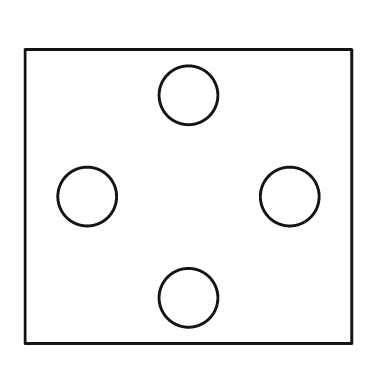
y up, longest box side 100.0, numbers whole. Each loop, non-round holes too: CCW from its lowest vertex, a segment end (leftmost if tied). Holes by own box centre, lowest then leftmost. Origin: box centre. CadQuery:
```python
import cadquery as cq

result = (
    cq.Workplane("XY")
    .moveTo(-50.0, -45.0)
    .lineTo(50.0, -45.0)
    .lineTo(50.0, 45.0)
    .lineTo(-50.0, 45.0)
    .close()
    .moveTo(0.0, -31.0)
    .circle(9.0)
    .moveTo(-31.0, 0.0)
    .circle(9.0)
    .moveTo(31.0, 0.0)
    .circle(9.0)
    .moveTo(0.0, 31.0)
    .circle(9.0)
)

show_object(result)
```